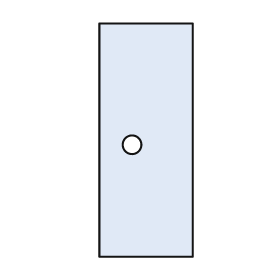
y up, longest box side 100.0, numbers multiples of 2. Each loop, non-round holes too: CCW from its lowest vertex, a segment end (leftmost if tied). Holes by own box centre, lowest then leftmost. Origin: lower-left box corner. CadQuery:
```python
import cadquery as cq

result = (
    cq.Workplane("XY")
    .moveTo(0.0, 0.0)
    .lineTo(40.0, 0.0)
    .lineTo(40.0, 100.0)
    .lineTo(0.0, 100.0)
    .close()
    .moveTo(14.0, 48.0)
    .circle(4.0)
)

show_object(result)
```